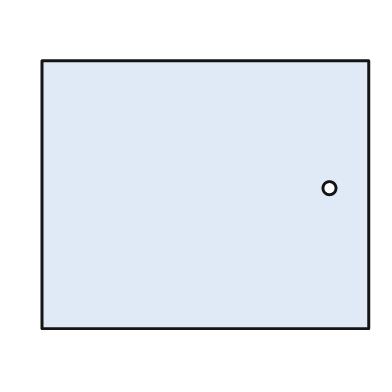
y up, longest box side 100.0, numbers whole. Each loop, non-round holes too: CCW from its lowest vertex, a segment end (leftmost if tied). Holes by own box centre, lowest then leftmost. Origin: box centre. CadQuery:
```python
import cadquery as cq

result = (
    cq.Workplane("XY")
    .moveTo(-50.0, -41.0)
    .lineTo(50.0, -41.0)
    .lineTo(50.0, 41.0)
    .lineTo(-50.0, 41.0)
    .close()
    .moveTo(38.0, 2.0)
    .circle(2.0)
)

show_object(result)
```